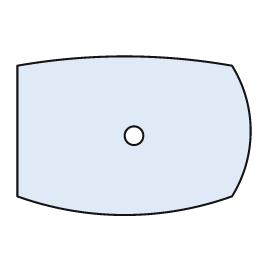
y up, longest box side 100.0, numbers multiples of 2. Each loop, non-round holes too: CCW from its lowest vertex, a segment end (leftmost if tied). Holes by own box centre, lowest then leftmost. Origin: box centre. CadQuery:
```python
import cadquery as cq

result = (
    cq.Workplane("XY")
    .moveTo(-50.0, -26.0)
    .threePointArc((-4.0, -34.0), (42.0, -26.0))
    .threePointArc((50.0, 2.0), (42.0, 30.0))
    .threePointArc((-4.0, 34.0), (-50.0, 30.0))
    .close()
    .moveTo(0.0, 0.0)
    .circle(4.0)
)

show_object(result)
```